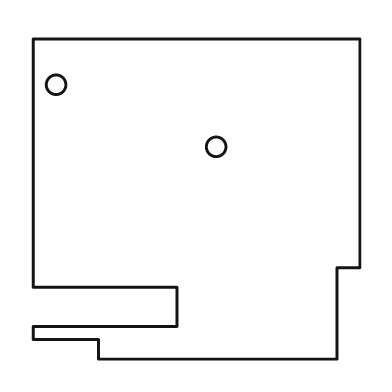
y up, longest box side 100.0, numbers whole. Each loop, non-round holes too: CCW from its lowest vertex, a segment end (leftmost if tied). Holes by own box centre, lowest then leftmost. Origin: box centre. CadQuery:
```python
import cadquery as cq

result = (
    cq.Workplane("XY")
    .moveTo(-30.0, -49.0)
    .lineTo(43.0, -49.0)
    .lineTo(43.0, -21.0)
    .lineTo(50.0, -21.0)
    .lineTo(50.0, 49.0)
    .lineTo(-50.0, 49.0)
    .lineTo(-50.0, -27.0)
    .lineTo(-6.0, -27.0)
    .lineTo(-6.0, -39.0)
    .lineTo(-50.0, -39.0)
    .lineTo(-50.0, -43.0)
    .lineTo(-30.0, -43.0)
    .close()
    .moveTo(6.0, 16.0)
    .circle(3.0)
    .moveTo(-43.0, 35.0)
    .circle(3.0)
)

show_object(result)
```